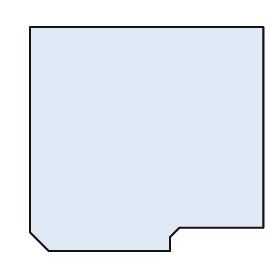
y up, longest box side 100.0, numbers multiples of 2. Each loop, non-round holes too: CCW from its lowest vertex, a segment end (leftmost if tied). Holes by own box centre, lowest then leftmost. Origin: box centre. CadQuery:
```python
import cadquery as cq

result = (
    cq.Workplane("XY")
    .moveTo(-42.0, -48.0)
    .lineTo(10.0, -48.0)
    .lineTo(10.0, -42.0)
    .lineTo(14.0, -38.0)
    .lineTo(50.0, -38.0)
    .lineTo(50.0, 48.0)
    .lineTo(-50.0, 48.0)
    .lineTo(-50.0, -40.0)
    .close()
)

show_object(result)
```